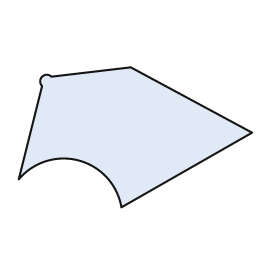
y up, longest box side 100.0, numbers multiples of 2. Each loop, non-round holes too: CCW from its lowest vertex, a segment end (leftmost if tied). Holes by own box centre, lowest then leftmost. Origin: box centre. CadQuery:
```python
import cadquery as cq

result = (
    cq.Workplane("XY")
    .moveTo(-6.0, -30.0)
    .lineTo(50.0, 2.0)
    .lineTo(-2.0, 30.0)
    .lineTo(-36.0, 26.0)
    .threePointArc((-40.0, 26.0), (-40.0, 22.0))
    .lineTo(-50.0, -18.0)
    .threePointArc((-24.0, -10.0), (-6.0, -30.0))
    .close()
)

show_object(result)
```